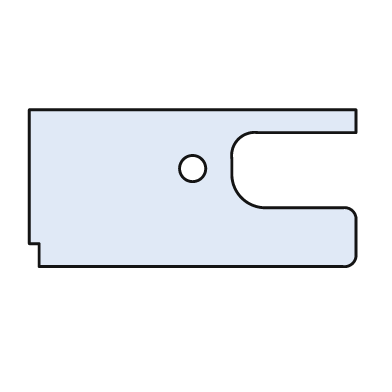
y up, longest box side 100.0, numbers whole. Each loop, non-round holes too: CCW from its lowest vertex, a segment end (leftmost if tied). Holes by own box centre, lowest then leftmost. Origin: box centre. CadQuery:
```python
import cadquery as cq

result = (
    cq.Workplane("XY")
    .moveTo(-47.0, -24.0)
    .lineTo(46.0, -24.0)
    .threePointArc((49.0, -23.0), (50.0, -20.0))
    .lineTo(50.0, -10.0)
    .threePointArc((49.0, -7.0), (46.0, -6.0))
    .lineTo(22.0, -6.0)
    .threePointArc((15.0, -3.0), (12.0, 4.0))
    .lineTo(12.0, 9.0)
    .threePointArc((14.0, 15.0), (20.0, 17.0))
    .lineTo(50.0, 17.0)
    .lineTo(50.0, 24.0)
    .lineTo(-50.0, 24.0)
    .lineTo(-50.0, -17.0)
    .lineTo(-47.0, -17.0)
    .close()
    .moveTo(0.0, 6.0)
    .circle(4.0)
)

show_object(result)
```